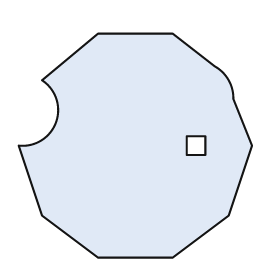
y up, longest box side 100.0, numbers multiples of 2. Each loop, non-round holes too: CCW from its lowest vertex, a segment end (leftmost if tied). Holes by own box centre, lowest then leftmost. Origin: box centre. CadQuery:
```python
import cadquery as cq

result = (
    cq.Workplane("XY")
    .moveTo(-16.0, -48.0)
    .lineTo(16.0, -48.0)
    .lineTo(40.0, -30.0)
    .lineTo(50.0, 0.0)
    .lineTo(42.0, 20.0)
    .threePointArc((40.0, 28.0), (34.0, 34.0))
    .lineTo(16.0, 48.0)
    .lineTo(-16.0, 48.0)
    .lineTo(-40.0, 28.0)
    .threePointArc((-34.0, 10.0), (-50.0, 0.0))
    .lineTo(-40.0, -30.0)
    .close()
    .moveTo(22.0, -4.0)
    .lineTo(30.0, -4.0)
    .lineTo(30.0, 4.0)
    .lineTo(22.0, 4.0)
    .close()
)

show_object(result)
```